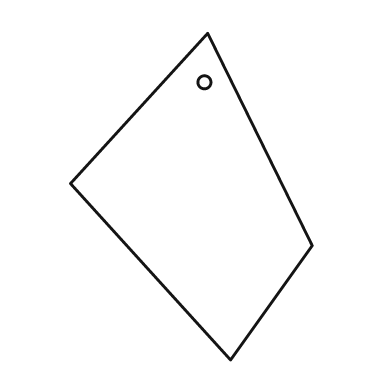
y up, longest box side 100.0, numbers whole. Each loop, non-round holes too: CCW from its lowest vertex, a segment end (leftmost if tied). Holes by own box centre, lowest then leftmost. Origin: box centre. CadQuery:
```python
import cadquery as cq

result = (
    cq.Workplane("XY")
    .moveTo(12.0, -50.0)
    .lineTo(37.0, -15.0)
    .lineTo(5.0, 50.0)
    .lineTo(-37.0, 4.0)
    .close()
    .moveTo(4.0, 35.0)
    .circle(2.0)
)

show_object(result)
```